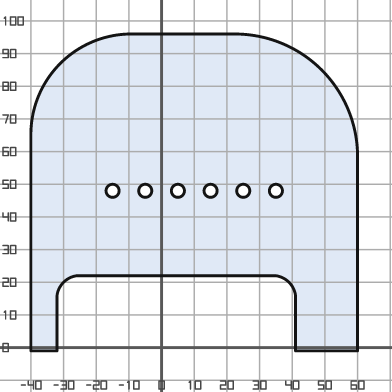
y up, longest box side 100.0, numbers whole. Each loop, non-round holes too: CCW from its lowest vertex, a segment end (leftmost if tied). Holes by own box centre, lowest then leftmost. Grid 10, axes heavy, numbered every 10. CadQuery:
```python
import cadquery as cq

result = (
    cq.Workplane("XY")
    .moveTo(-40.0, -1.0)
    .lineTo(-32.0, -1.0)
    .lineTo(-32.0, 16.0)
    .threePointArc((-30.0, 20.0), (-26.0, 22.0))
    .lineTo(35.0, 22.0)
    .threePointArc((39.0, 20.0), (41.0, 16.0))
    .lineTo(41.0, -1.0)
    .lineTo(60.0, -1.0)
    .lineTo(60.0, 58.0)
    .threePointArc((49.0, 85.0), (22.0, 96.0))
    .lineTo(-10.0, 96.0)
    .threePointArc((-31.0, 87.0), (-40.0, 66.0))
    .close()
    .moveTo(-15.0, 48.0)
    .circle(2.0)
    .moveTo(-5.0, 48.0)
    .circle(2.0)
    .moveTo(5.0, 48.0)
    .circle(2.0)
    .moveTo(15.0, 48.0)
    .circle(2.0)
    .moveTo(25.0, 48.0)
    .circle(2.0)
    .moveTo(35.0, 48.0)
    .circle(2.0)
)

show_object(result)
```